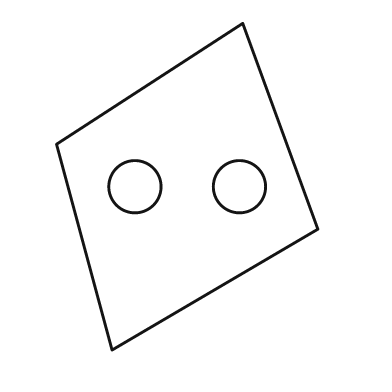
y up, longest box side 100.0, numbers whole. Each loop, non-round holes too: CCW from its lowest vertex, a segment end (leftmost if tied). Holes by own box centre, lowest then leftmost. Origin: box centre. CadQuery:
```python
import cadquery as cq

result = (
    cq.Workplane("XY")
    .moveTo(-23.0, -50.0)
    .lineTo(40.0, -13.0)
    .lineTo(17.0, 50.0)
    .lineTo(-40.0, 13.0)
    .close()
    .moveTo(-16.0, 0.0)
    .circle(8.0)
    .moveTo(16.0, 0.0)
    .circle(8.0)
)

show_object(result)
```